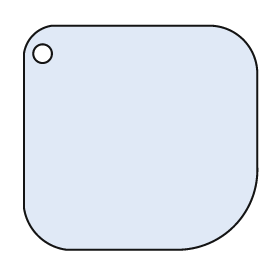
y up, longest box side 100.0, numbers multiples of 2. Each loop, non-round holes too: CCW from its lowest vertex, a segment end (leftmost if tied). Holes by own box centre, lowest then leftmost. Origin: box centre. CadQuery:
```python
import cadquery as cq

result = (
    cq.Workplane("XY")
    .moveTo(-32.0, -48.0)
    .lineTo(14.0, -48.0)
    .threePointArc((40.0, -38.0), (50.0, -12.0))
    .lineTo(50.0, 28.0)
    .threePointArc((44.0, 42.0), (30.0, 48.0))
    .lineTo(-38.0, 48.0)
    .threePointArc((-46.0, 44.0), (-50.0, 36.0))
    .lineTo(-50.0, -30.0)
    .threePointArc((-44.0, -42.0), (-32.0, -48.0))
    .close()
    .moveTo(-42.0, 36.0)
    .circle(4.0)
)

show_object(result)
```